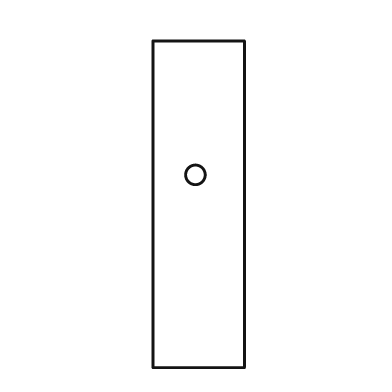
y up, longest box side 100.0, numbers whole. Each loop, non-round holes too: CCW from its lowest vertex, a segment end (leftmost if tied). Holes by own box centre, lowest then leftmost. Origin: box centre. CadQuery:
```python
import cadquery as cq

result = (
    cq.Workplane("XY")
    .moveTo(-14.0, -50.0)
    .lineTo(14.0, -50.0)
    .lineTo(14.0, 50.0)
    .lineTo(-14.0, 50.0)
    .close()
    .moveTo(-1.0, 9.0)
    .circle(3.0)
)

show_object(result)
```